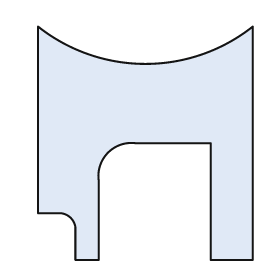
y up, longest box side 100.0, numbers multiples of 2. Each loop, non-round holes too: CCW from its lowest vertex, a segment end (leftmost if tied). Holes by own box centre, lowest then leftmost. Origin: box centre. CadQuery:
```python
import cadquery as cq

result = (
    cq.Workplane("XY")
    .moveTo(-30.0, -50.0)
    .lineTo(-20.0, -50.0)
    .lineTo(-20.0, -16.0)
    .threePointArc((-16.0, -4.0), (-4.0, 0.0))
    .lineTo(28.0, 0.0)
    .lineTo(28.0, -50.0)
    .lineTo(46.0, -50.0)
    .lineTo(46.0, 50.0)
    .threePointArc((0.0, 34.0), (-46.0, 50.0))
    .lineTo(-46.0, -30.0)
    .lineTo(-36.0, -30.0)
    .threePointArc((-32.0, -32.0), (-30.0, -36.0))
    .close()
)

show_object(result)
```